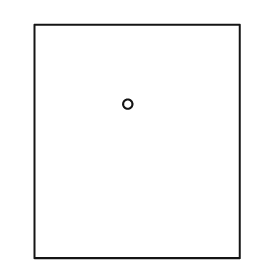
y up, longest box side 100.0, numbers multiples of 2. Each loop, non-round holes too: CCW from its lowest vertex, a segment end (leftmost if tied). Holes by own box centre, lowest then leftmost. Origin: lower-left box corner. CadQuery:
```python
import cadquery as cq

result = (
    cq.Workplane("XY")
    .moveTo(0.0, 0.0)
    .lineTo(88.0, 0.0)
    .lineTo(88.0, 100.0)
    .lineTo(0.0, 100.0)
    .close()
    .moveTo(40.0, 66.0)
    .circle(2.0)
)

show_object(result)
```